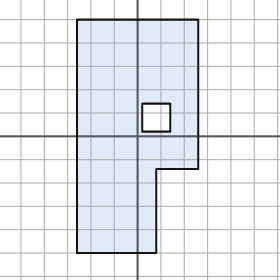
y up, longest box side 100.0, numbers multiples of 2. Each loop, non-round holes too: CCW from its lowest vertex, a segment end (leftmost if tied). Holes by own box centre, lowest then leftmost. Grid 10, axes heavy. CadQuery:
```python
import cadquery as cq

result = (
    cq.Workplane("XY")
    .moveTo(-26.0, -50.0)
    .lineTo(8.0, -50.0)
    .lineTo(8.0, -14.0)
    .lineTo(26.0, -14.0)
    .lineTo(26.0, 50.0)
    .lineTo(-26.0, 50.0)
    .close()
    .moveTo(2.0, 2.0)
    .lineTo(14.0, 2.0)
    .lineTo(14.0, 14.0)
    .lineTo(2.0, 14.0)
    .close()
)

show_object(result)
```